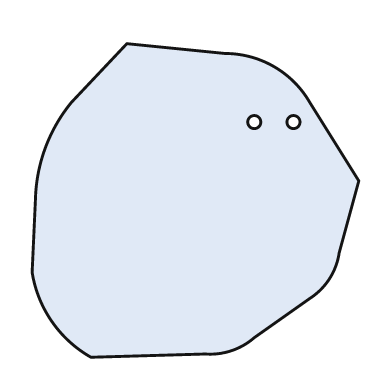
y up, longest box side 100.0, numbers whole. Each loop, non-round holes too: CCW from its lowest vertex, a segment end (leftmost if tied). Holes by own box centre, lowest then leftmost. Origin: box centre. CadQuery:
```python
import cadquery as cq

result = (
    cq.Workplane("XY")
    .moveTo(-32.0, -48.0)
    .lineTo(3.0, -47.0)
    .threePointArc((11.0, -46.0), (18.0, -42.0))
    .lineTo(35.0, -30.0)
    .threePointArc((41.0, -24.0), (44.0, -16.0))
    .lineTo(50.0, 6.0)
    .lineTo(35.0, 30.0)
    .threePointArc((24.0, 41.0), (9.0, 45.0))
    .lineTo(-21.0, 48.0)
    .lineTo(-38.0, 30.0)
    .threePointArc((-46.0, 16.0), (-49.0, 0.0))
    .lineTo(-50.0, -22.0)
    .threePointArc((-44.0, -37.0), (-32.0, -48.0))
    .close()
    .moveTo(18.0, 24.0)
    .circle(2.0)
    .moveTo(30.0, 24.0)
    .circle(2.0)
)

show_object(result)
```